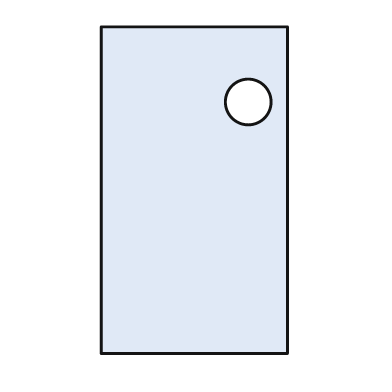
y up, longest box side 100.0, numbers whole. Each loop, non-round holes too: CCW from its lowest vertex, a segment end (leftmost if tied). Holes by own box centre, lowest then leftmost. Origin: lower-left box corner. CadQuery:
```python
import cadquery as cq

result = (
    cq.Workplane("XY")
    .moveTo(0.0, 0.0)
    .lineTo(57.0, 0.0)
    .lineTo(57.0, 100.0)
    .lineTo(0.0, 100.0)
    .close()
    .moveTo(45.0, 77.0)
    .circle(7.0)
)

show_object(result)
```